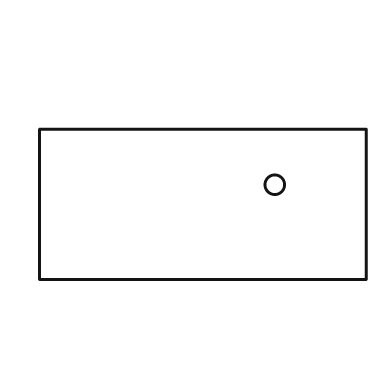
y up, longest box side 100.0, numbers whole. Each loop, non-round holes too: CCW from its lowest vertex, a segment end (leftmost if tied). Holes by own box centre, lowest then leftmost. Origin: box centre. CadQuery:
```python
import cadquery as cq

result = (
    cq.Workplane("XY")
    .moveTo(-50.0, -23.0)
    .lineTo(50.0, -23.0)
    .lineTo(50.0, 23.0)
    .lineTo(-50.0, 23.0)
    .close()
    .moveTo(22.0, 6.0)
    .circle(3.0)
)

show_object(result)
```